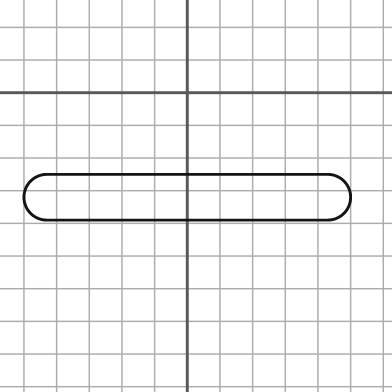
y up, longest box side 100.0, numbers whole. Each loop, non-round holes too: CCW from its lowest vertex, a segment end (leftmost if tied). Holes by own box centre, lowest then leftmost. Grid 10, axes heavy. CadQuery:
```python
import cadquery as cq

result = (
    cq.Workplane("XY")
    .moveTo(-43.0, -39.0)
    .lineTo(43.0, -39.0)
    .threePointArc((50.0, -32.0), (43.0, -25.0))
    .lineTo(-43.0, -25.0)
    .threePointArc((-50.0, -32.0), (-43.0, -39.0))
    .close()
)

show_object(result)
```